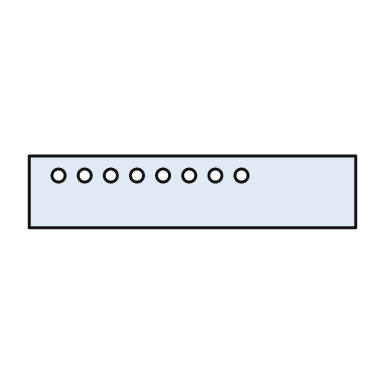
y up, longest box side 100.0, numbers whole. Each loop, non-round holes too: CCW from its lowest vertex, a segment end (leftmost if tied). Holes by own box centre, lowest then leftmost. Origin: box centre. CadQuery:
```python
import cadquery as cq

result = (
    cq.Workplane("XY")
    .moveTo(-50.0, -11.0)
    .lineTo(50.0, -11.0)
    .lineTo(50.0, 11.0)
    .lineTo(-50.0, 11.0)
    .close()
    .moveTo(-41.0, 5.0)
    .circle(2.0)
    .moveTo(-33.0, 5.0)
    .circle(2.0)
    .moveTo(-25.0, 5.0)
    .circle(2.0)
    .moveTo(-17.0, 5.0)
    .circle(2.0)
    .moveTo(-9.0, 5.0)
    .circle(2.0)
    .moveTo(-1.0, 5.0)
    .circle(2.0)
    .moveTo(7.0, 5.0)
    .circle(2.0)
    .moveTo(15.0, 5.0)
    .circle(2.0)
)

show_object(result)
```